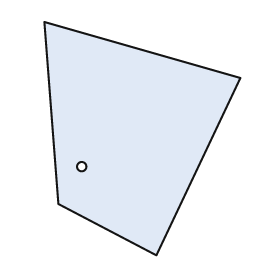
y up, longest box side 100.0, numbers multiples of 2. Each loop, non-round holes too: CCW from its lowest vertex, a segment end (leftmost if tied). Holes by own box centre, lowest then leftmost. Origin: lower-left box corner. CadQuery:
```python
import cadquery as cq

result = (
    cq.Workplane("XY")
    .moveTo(48.0, 0.0)
    .lineTo(84.0, 76.0)
    .lineTo(0.0, 100.0)
    .lineTo(6.0, 22.0)
    .close()
    .moveTo(16.0, 38.0)
    .circle(2.0)
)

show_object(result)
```